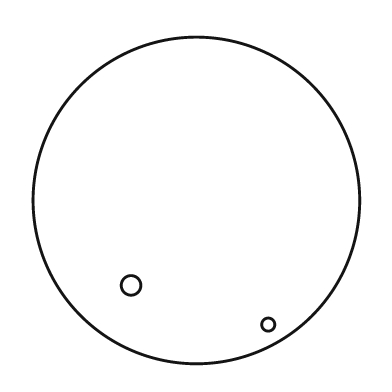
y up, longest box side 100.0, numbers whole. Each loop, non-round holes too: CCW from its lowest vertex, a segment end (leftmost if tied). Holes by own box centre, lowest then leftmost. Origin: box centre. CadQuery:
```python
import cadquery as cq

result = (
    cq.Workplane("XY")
    .moveTo(0.0, 0.0)
    .circle(50.0)
    .moveTo(22.0, -38.0)
    .circle(2.0)
    .moveTo(-20.0, -26.0)
    .circle(3.0)
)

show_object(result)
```